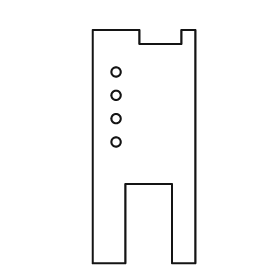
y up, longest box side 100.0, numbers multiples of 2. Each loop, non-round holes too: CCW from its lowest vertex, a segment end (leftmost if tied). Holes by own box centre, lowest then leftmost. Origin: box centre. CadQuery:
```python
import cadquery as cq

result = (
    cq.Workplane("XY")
    .moveTo(-22.0, -50.0)
    .lineTo(-8.0, -50.0)
    .lineTo(-8.0, -16.0)
    .lineTo(12.0, -16.0)
    .lineTo(12.0, -50.0)
    .lineTo(22.0, -50.0)
    .lineTo(22.0, 50.0)
    .lineTo(16.0, 50.0)
    .lineTo(16.0, 44.0)
    .lineTo(-2.0, 44.0)
    .lineTo(-2.0, 50.0)
    .lineTo(-22.0, 50.0)
    .close()
    .moveTo(-12.0, 2.0)
    .circle(2.0)
    .moveTo(-12.0, 12.0)
    .circle(2.0)
    .moveTo(-12.0, 22.0)
    .circle(2.0)
    .moveTo(-12.0, 32.0)
    .circle(2.0)
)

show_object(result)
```